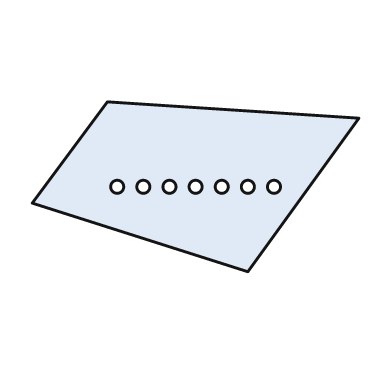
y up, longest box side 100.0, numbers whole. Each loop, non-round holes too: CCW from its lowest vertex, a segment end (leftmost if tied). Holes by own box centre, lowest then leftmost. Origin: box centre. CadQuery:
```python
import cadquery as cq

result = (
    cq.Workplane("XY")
    .moveTo(16.0, -26.0)
    .lineTo(50.0, 21.0)
    .lineTo(-27.0, 26.0)
    .lineTo(-50.0, -5.0)
    .close()
    .moveTo(-24.0, 0.0)
    .circle(2.0)
    .moveTo(-16.0, 0.0)
    .circle(2.0)
    .moveTo(-8.0, 0.0)
    .circle(2.0)
    .moveTo(0.0, 0.0)
    .circle(2.0)
    .moveTo(8.0, 0.0)
    .circle(2.0)
    .moveTo(16.0, 0.0)
    .circle(2.0)
    .moveTo(24.0, 0.0)
    .circle(2.0)
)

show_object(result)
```